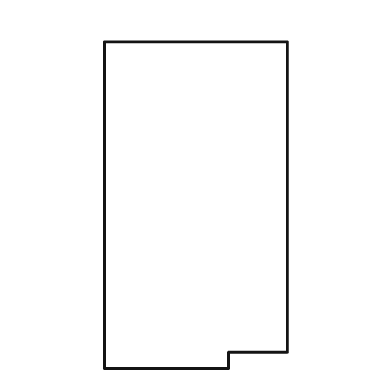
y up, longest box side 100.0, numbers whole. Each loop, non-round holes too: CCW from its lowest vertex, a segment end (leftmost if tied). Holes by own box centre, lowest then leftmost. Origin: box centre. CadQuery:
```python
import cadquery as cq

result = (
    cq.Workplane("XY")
    .moveTo(-28.0, -50.0)
    .lineTo(10.0, -50.0)
    .lineTo(10.0, -45.0)
    .lineTo(28.0, -45.0)
    .lineTo(28.0, 50.0)
    .lineTo(-28.0, 50.0)
    .close()
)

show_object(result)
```